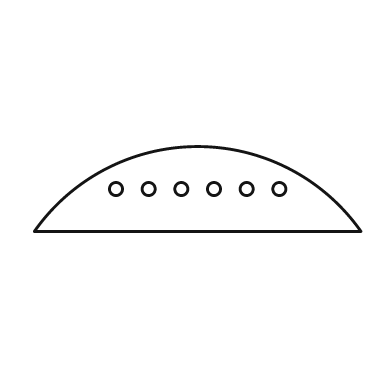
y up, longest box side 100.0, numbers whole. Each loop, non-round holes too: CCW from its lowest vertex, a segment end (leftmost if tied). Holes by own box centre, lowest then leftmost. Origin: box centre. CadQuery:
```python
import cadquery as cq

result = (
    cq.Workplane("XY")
    .moveTo(-50.0, -13.0)
    .lineTo(50.0, -13.0)
    .threePointArc((0.0, 13.0), (-50.0, -13.0))
    .close()
    .moveTo(-25.0, 0.0)
    .circle(2.0)
    .moveTo(-15.0, 0.0)
    .circle(2.0)
    .moveTo(-5.0, 0.0)
    .circle(2.0)
    .moveTo(5.0, 0.0)
    .circle(2.0)
    .moveTo(15.0, 0.0)
    .circle(2.0)
    .moveTo(25.0, 0.0)
    .circle(2.0)
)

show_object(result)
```